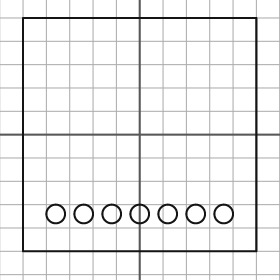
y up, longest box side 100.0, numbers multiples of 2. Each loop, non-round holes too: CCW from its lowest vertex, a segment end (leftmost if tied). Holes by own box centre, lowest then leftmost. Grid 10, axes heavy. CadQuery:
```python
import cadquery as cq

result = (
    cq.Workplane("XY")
    .moveTo(-50.0, -50.0)
    .lineTo(50.0, -50.0)
    .lineTo(50.0, 50.0)
    .lineTo(-50.0, 50.0)
    .close()
    .moveTo(-36.0, -34.0)
    .circle(4.0)
    .moveTo(-24.0, -34.0)
    .circle(4.0)
    .moveTo(-12.0, -34.0)
    .circle(4.0)
    .moveTo(0.0, -34.0)
    .circle(4.0)
    .moveTo(12.0, -34.0)
    .circle(4.0)
    .moveTo(24.0, -34.0)
    .circle(4.0)
    .moveTo(36.0, -34.0)
    .circle(4.0)
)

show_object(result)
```